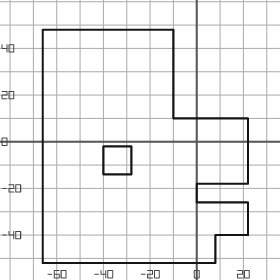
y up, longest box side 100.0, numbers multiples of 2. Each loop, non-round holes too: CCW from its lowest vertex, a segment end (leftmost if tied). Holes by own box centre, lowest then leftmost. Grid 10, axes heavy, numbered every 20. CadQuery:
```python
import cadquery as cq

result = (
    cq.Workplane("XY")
    .moveTo(-66.0, -52.0)
    .lineTo(8.0, -52.0)
    .lineTo(8.0, -40.0)
    .lineTo(22.0, -40.0)
    .lineTo(22.0, -26.0)
    .lineTo(0.0, -26.0)
    .lineTo(0.0, -18.0)
    .lineTo(22.0, -18.0)
    .lineTo(22.0, 10.0)
    .lineTo(-10.0, 10.0)
    .lineTo(-10.0, 48.0)
    .lineTo(-66.0, 48.0)
    .close()
    .moveTo(-40.0, -14.0)
    .lineTo(-28.0, -14.0)
    .lineTo(-28.0, -2.0)
    .lineTo(-40.0, -2.0)
    .close()
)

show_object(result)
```